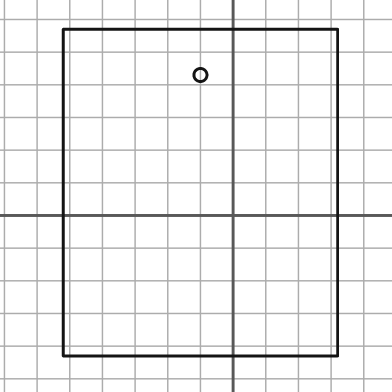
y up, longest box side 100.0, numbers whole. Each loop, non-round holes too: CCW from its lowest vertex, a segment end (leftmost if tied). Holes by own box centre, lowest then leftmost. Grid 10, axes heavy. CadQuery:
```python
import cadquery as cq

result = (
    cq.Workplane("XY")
    .moveTo(-52.0, -43.0)
    .lineTo(32.0, -43.0)
    .lineTo(32.0, 57.0)
    .lineTo(-52.0, 57.0)
    .close()
    .moveTo(-10.0, 43.0)
    .circle(2.0)
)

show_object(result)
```